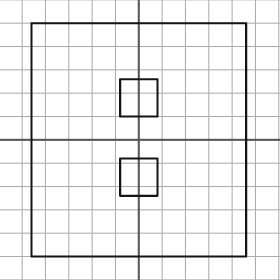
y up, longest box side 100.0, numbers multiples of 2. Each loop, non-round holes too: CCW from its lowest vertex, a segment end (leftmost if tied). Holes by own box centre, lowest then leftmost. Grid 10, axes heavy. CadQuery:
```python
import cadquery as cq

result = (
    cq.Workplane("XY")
    .moveTo(-46.0, -50.0)
    .lineTo(46.0, -50.0)
    .lineTo(46.0, 50.0)
    .lineTo(-46.0, 50.0)
    .close()
    .moveTo(-8.0, -24.0)
    .lineTo(8.0, -24.0)
    .lineTo(8.0, -8.0)
    .lineTo(-8.0, -8.0)
    .close()
    .moveTo(-8.0, 10.0)
    .lineTo(8.0, 10.0)
    .lineTo(8.0, 26.0)
    .lineTo(-8.0, 26.0)
    .close()
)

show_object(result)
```